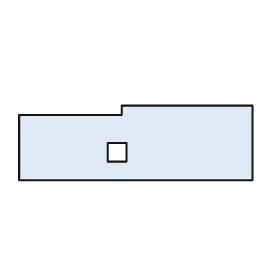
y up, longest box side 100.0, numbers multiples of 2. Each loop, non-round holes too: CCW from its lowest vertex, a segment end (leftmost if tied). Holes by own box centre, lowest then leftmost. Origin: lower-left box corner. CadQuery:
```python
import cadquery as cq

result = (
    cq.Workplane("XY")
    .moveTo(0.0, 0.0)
    .lineTo(100.0, 0.0)
    .lineTo(100.0, 32.0)
    .lineTo(44.0, 32.0)
    .lineTo(44.0, 28.0)
    .lineTo(0.0, 28.0)
    .close()
    .moveTo(38.0, 8.0)
    .lineTo(46.0, 8.0)
    .lineTo(46.0, 16.0)
    .lineTo(38.0, 16.0)
    .close()
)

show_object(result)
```